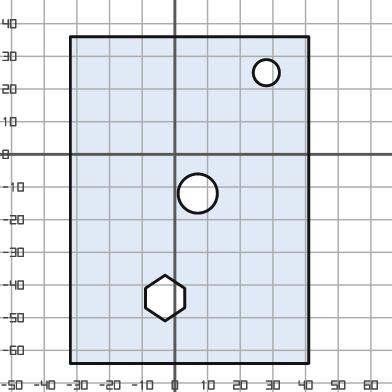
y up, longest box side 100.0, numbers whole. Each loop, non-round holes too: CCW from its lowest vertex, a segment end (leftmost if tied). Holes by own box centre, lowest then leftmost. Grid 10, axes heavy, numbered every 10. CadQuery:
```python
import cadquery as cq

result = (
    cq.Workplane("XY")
    .moveTo(-32.0, -64.0)
    .lineTo(41.0, -64.0)
    .lineTo(41.0, 36.0)
    .lineTo(-32.0, 36.0)
    .close()
    .moveTo(-3.0, -51.0)
    .lineTo(3.0, -47.0)
    .lineTo(3.0, -41.0)
    .lineTo(-3.0, -37.0)
    .lineTo(-9.0, -41.0)
    .lineTo(-9.0, -47.0)
    .close()
    .moveTo(7.0, -12.0)
    .circle(6.0)
    .moveTo(28.0, 25.0)
    .circle(4.0)
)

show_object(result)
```